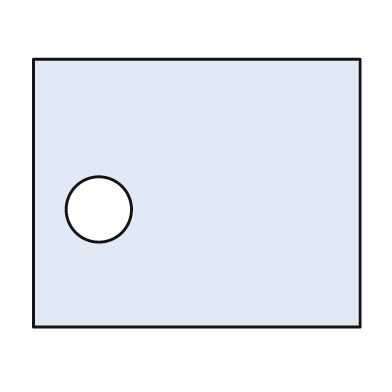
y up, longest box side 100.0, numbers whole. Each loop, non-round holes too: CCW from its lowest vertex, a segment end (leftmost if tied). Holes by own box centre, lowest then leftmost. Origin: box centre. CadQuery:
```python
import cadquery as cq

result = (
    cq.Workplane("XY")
    .moveTo(-50.0, -41.0)
    .lineTo(50.0, -41.0)
    .lineTo(50.0, 41.0)
    .lineTo(-50.0, 41.0)
    .close()
    .moveTo(-30.0, -5.0)
    .circle(10.0)
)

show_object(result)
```